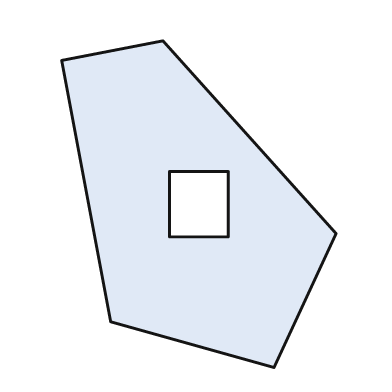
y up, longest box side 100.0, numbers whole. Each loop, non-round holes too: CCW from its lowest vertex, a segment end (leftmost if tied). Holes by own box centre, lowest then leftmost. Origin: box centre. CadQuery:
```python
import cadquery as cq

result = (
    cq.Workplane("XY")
    .moveTo(23.0, -50.0)
    .lineTo(42.0, -9.0)
    .lineTo(-11.0, 50.0)
    .lineTo(-42.0, 44.0)
    .lineTo(-27.0, -36.0)
    .close()
    .moveTo(-9.0, -10.0)
    .lineTo(9.0, -10.0)
    .lineTo(9.0, 10.0)
    .lineTo(-9.0, 10.0)
    .close()
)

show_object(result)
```